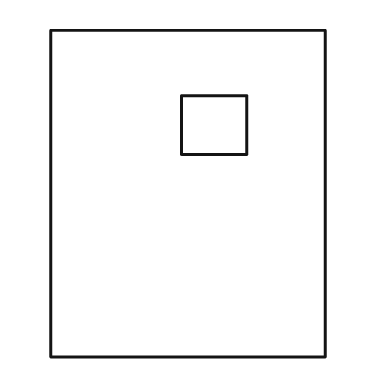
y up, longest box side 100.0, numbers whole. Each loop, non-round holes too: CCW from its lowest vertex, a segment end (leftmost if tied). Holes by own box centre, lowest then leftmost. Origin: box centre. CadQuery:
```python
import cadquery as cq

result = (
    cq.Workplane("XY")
    .moveTo(-42.0, -50.0)
    .lineTo(42.0, -50.0)
    .lineTo(42.0, 50.0)
    .lineTo(-42.0, 50.0)
    .close()
    .moveTo(-2.0, 12.0)
    .lineTo(18.0, 12.0)
    .lineTo(18.0, 30.0)
    .lineTo(-2.0, 30.0)
    .close()
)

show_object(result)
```